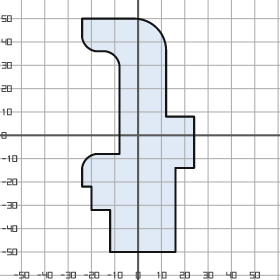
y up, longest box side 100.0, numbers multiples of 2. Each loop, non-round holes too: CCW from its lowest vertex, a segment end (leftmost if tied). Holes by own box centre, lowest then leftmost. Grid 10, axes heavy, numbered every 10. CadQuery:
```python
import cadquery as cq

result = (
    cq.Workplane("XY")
    .moveTo(-12.0, -50.0)
    .lineTo(16.0, -50.0)
    .lineTo(16.0, -14.0)
    .lineTo(24.0, -14.0)
    .lineTo(24.0, 8.0)
    .lineTo(12.0, 8.0)
    .lineTo(12.0, 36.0)
    .threePointArc((8.0, 46.0), (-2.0, 50.0))
    .lineTo(-24.0, 50.0)
    .lineTo(-24.0, 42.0)
    .threePointArc((-22.0, 38.0), (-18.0, 36.0))
    .lineTo(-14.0, 36.0)
    .threePointArc((-10.0, 34.0), (-8.0, 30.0))
    .lineTo(-8.0, -8.0)
    .lineTo(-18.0, -8.0)
    .threePointArc((-22.0, -10.0), (-24.0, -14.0))
    .lineTo(-24.0, -22.0)
    .lineTo(-20.0, -22.0)
    .lineTo(-20.0, -32.0)
    .lineTo(-12.0, -32.0)
    .close()
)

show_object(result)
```